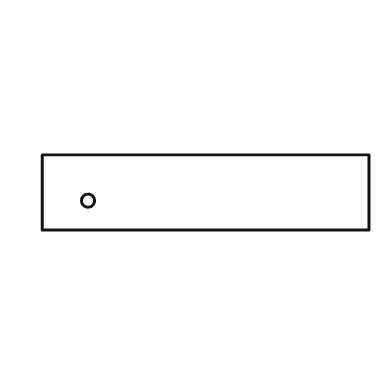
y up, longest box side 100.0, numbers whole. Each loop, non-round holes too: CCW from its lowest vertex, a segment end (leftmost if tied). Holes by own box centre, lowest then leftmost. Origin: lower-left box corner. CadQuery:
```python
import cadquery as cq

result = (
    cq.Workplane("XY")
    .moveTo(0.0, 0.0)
    .lineTo(100.0, 0.0)
    .lineTo(100.0, 23.0)
    .lineTo(0.0, 23.0)
    .close()
    .moveTo(14.0, 9.0)
    .circle(2.0)
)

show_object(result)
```